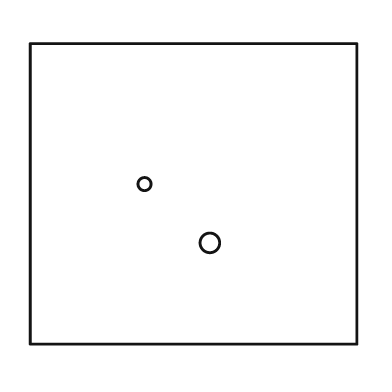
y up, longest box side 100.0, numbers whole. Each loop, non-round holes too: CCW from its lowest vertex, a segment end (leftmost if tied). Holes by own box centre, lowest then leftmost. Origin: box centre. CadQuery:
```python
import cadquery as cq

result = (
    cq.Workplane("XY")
    .moveTo(-50.0, -46.0)
    .lineTo(50.0, -46.0)
    .lineTo(50.0, 46.0)
    .lineTo(-50.0, 46.0)
    .close()
    .moveTo(5.0, -15.0)
    .circle(3.0)
    .moveTo(-15.0, 3.0)
    .circle(2.0)
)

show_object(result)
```